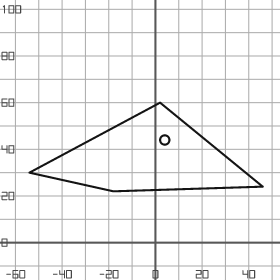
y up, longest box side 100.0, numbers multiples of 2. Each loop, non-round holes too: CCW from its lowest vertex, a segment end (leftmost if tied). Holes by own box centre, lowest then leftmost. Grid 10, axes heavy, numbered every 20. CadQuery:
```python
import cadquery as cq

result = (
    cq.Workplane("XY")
    .moveTo(-18.0, 22.0)
    .lineTo(46.0, 24.0)
    .lineTo(2.0, 60.0)
    .lineTo(-54.0, 30.0)
    .close()
    .moveTo(4.0, 44.0)
    .circle(2.0)
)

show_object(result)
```